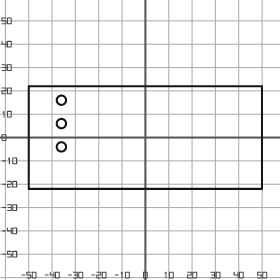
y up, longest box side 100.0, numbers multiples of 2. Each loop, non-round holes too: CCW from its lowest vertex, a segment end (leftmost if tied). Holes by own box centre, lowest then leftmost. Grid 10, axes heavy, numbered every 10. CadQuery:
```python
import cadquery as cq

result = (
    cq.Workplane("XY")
    .moveTo(-50.0, -22.0)
    .lineTo(50.0, -22.0)
    .lineTo(50.0, 22.0)
    .lineTo(-50.0, 22.0)
    .close()
    .moveTo(-36.0, -4.0)
    .circle(2.0)
    .moveTo(-36.0, 6.0)
    .circle(2.0)
    .moveTo(-36.0, 16.0)
    .circle(2.0)
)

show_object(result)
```